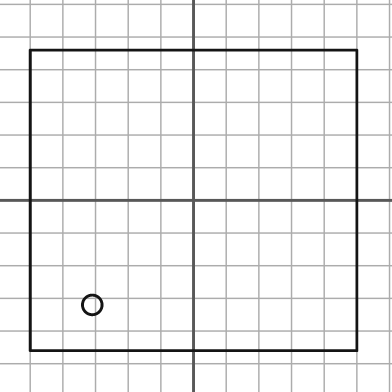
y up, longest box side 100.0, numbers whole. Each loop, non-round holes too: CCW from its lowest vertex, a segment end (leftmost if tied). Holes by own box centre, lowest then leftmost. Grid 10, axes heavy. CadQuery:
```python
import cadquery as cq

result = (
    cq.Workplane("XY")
    .moveTo(-50.0, -46.0)
    .lineTo(50.0, -46.0)
    .lineTo(50.0, 46.0)
    .lineTo(-50.0, 46.0)
    .close()
    .moveTo(-31.0, -32.0)
    .circle(3.0)
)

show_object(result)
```